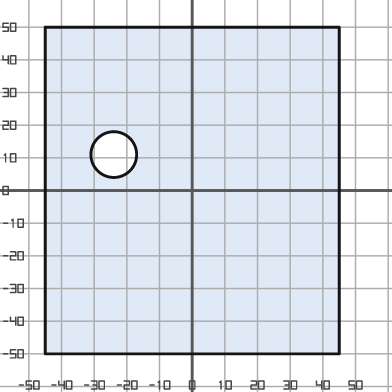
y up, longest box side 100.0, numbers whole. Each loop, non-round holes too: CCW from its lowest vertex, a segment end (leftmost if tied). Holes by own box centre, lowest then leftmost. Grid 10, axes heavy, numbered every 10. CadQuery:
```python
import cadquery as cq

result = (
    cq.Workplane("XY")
    .moveTo(-45.0, -50.0)
    .lineTo(45.0, -50.0)
    .lineTo(45.0, 50.0)
    .lineTo(-45.0, 50.0)
    .close()
    .moveTo(-24.0, 11.0)
    .circle(7.0)
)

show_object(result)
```